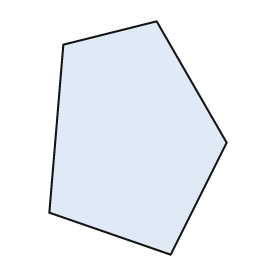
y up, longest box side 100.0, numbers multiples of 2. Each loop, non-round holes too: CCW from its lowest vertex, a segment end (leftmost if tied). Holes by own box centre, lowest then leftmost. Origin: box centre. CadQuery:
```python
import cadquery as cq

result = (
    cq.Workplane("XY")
    .moveTo(14.0, -50.0)
    .lineTo(38.0, -2.0)
    .lineTo(8.0, 50.0)
    .lineTo(-32.0, 40.0)
    .lineTo(-38.0, -32.0)
    .close()
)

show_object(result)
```